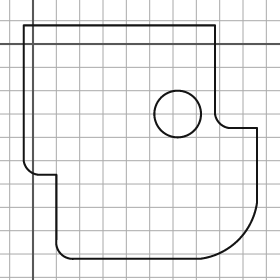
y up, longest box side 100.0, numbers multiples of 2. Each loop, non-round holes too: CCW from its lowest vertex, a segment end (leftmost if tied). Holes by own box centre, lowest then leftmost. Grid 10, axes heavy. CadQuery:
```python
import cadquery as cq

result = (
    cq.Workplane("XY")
    .moveTo(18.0, -92.0)
    .lineTo(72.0, -92.0)
    .threePointArc((88.0, -84.0), (96.0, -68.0))
    .lineTo(96.0, -36.0)
    .lineTo(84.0, -36.0)
    .threePointArc((80.0, -34.0), (78.0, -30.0))
    .lineTo(78.0, 8.0)
    .lineTo(-4.0, 8.0)
    .lineTo(-4.0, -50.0)
    .threePointArc((-2.0, -54.0), (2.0, -56.0))
    .lineTo(10.0, -56.0)
    .lineTo(10.0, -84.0)
    .threePointArc((12.0, -90.0), (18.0, -92.0))
    .close()
    .moveTo(62.0, -30.0)
    .circle(10.0)
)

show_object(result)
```